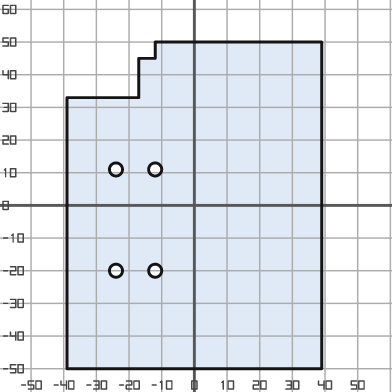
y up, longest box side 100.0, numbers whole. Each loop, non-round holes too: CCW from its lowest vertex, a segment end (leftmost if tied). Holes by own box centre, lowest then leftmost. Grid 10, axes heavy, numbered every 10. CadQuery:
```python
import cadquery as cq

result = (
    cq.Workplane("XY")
    .moveTo(-39.0, -50.0)
    .lineTo(39.0, -50.0)
    .lineTo(39.0, 50.0)
    .lineTo(-12.0, 50.0)
    .lineTo(-12.0, 45.0)
    .lineTo(-17.0, 45.0)
    .lineTo(-17.0, 33.0)
    .lineTo(-39.0, 33.0)
    .close()
    .moveTo(-24.0, -20.0)
    .circle(2.0)
    .moveTo(-12.0, -20.0)
    .circle(2.0)
    .moveTo(-24.0, 11.0)
    .circle(2.0)
    .moveTo(-12.0, 11.0)
    .circle(2.0)
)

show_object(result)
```